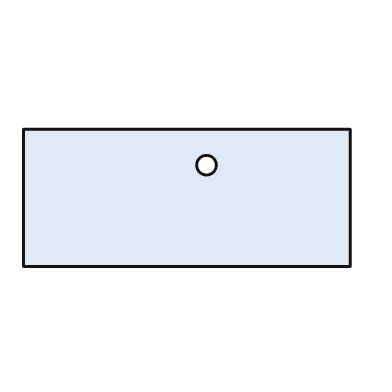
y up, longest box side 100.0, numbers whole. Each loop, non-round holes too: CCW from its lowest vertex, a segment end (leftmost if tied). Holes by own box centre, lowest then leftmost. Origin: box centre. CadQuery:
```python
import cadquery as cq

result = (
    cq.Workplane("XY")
    .moveTo(-50.0, -21.0)
    .lineTo(50.0, -21.0)
    .lineTo(50.0, 21.0)
    .lineTo(-50.0, 21.0)
    .close()
    .moveTo(6.0, 10.0)
    .circle(3.0)
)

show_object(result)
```